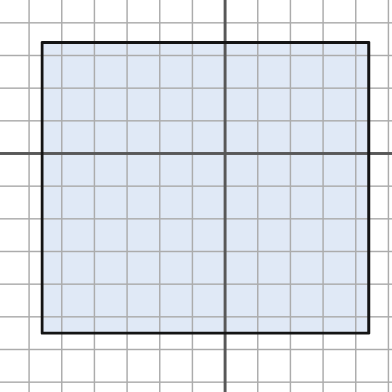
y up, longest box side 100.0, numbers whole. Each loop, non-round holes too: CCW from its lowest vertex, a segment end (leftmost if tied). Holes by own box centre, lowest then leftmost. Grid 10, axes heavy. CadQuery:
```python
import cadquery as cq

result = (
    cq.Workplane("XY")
    .moveTo(-56.0, -55.0)
    .lineTo(44.0, -55.0)
    .lineTo(44.0, 34.0)
    .lineTo(-56.0, 34.0)
    .close()
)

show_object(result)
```